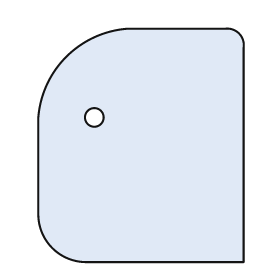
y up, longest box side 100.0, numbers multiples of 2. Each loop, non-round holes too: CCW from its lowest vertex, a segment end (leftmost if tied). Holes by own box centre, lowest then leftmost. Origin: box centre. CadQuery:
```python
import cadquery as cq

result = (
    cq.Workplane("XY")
    .moveTo(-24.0, -50.0)
    .lineTo(44.0, -50.0)
    .lineTo(44.0, 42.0)
    .threePointArc((42.0, 48.0), (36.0, 50.0))
    .lineTo(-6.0, 50.0)
    .threePointArc((-32.0, 38.0), (-44.0, 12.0))
    .lineTo(-44.0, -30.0)
    .threePointArc((-38.0, -44.0), (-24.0, -50.0))
    .close()
    .moveTo(-20.0, 12.0)
    .circle(4.0)
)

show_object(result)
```